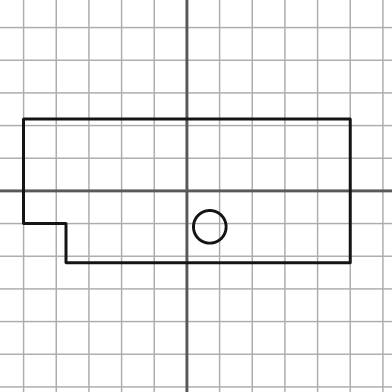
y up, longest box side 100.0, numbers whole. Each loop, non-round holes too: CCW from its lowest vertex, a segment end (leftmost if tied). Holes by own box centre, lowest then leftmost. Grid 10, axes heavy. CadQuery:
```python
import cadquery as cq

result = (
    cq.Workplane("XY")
    .moveTo(-37.0, -22.0)
    .lineTo(50.0, -22.0)
    .lineTo(50.0, 22.0)
    .lineTo(-50.0, 22.0)
    .lineTo(-50.0, -10.0)
    .lineTo(-37.0, -10.0)
    .close()
    .moveTo(7.0, -11.0)
    .circle(5.0)
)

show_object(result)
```